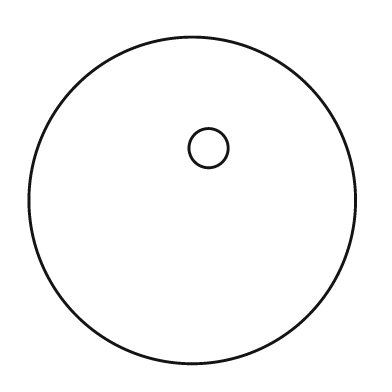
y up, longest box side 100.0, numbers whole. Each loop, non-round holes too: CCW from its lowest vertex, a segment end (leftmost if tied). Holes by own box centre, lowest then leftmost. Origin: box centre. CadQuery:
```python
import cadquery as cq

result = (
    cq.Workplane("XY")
    .moveTo(0.0, 0.0)
    .circle(50.0)
    .moveTo(5.0, 16.0)
    .circle(6.0)
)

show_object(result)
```